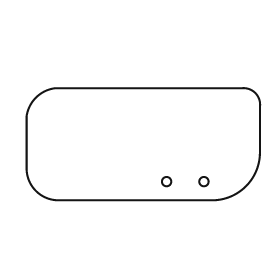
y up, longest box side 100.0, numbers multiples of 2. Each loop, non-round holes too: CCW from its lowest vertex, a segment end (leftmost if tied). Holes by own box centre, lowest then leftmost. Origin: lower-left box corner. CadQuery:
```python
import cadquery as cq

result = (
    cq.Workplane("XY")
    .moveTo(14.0, 0.0)
    .lineTo(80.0, 0.0)
    .threePointArc((94.0, 6.0), (100.0, 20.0))
    .lineTo(100.0, 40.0)
    .threePointArc((98.0, 46.0), (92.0, 48.0))
    .lineTo(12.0, 48.0)
    .threePointArc((4.0, 44.0), (0.0, 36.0))
    .lineTo(0.0, 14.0)
    .threePointArc((4.0, 4.0), (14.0, 0.0))
    .close()
    .moveTo(60.0, 8.0)
    .circle(2.0)
    .moveTo(76.0, 8.0)
    .circle(2.0)
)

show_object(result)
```